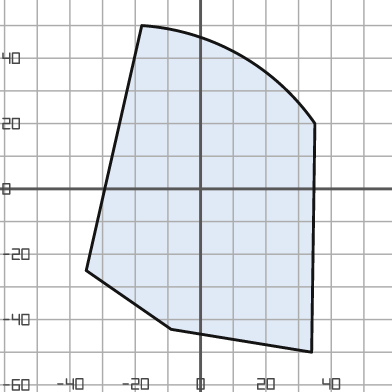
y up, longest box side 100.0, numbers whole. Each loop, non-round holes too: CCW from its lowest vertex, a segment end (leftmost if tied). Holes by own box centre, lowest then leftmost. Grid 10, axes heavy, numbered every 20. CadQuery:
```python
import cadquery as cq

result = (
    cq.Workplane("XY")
    .moveTo(34.0, -50.0)
    .lineTo(35.0, 20.0)
    .threePointArc((12.0, 41.0), (-18.0, 50.0))
    .lineTo(-35.0, -25.0)
    .lineTo(-9.0, -43.0)
    .close()
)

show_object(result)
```